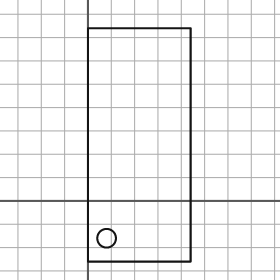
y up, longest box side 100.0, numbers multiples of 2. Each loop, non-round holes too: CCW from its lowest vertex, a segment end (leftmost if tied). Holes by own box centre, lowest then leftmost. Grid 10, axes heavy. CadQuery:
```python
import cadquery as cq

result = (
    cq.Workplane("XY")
    .moveTo(0.0, -26.0)
    .lineTo(44.0, -26.0)
    .lineTo(44.0, 74.0)
    .lineTo(0.0, 74.0)
    .close()
    .moveTo(8.0, -16.0)
    .circle(4.0)
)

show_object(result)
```